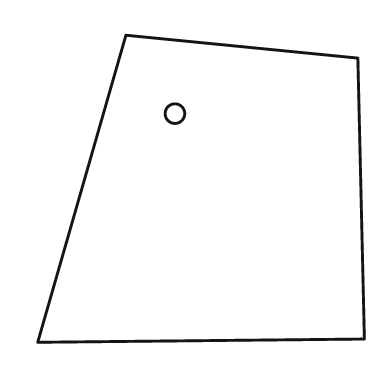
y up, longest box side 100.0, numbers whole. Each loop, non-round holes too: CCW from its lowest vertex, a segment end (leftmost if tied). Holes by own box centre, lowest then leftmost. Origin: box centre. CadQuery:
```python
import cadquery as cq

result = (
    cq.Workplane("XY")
    .moveTo(-50.0, -47.0)
    .lineTo(50.0, -46.0)
    .lineTo(48.0, 40.0)
    .lineTo(-23.0, 47.0)
    .close()
    .moveTo(-8.0, 23.0)
    .circle(3.0)
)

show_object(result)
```